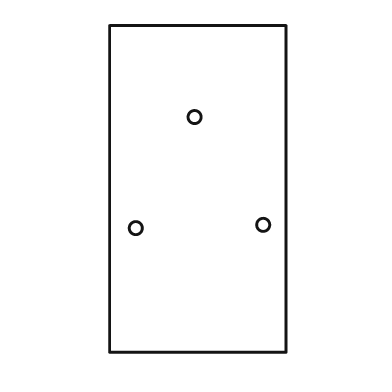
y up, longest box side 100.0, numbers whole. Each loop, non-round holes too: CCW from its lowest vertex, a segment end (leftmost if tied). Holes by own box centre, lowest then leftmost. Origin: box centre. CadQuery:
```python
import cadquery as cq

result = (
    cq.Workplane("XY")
    .moveTo(-27.0, -50.0)
    .lineTo(27.0, -50.0)
    .lineTo(27.0, 50.0)
    .lineTo(-27.0, 50.0)
    .close()
    .moveTo(-19.0, -12.0)
    .circle(2.0)
    .moveTo(20.0, -11.0)
    .circle(2.0)
    .moveTo(-1.0, 22.0)
    .circle(2.0)
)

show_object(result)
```